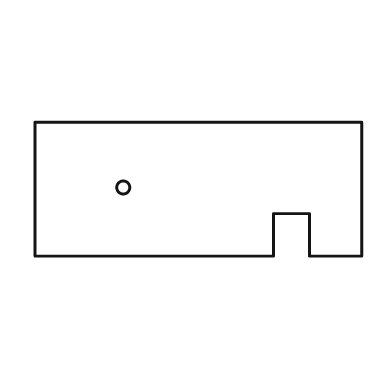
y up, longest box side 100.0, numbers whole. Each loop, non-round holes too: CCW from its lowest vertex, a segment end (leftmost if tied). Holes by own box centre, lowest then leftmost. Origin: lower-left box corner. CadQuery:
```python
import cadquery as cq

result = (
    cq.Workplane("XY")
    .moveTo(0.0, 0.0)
    .lineTo(73.0, 0.0)
    .lineTo(73.0, 13.0)
    .lineTo(84.0, 13.0)
    .lineTo(84.0, 0.0)
    .lineTo(100.0, 0.0)
    .lineTo(100.0, 41.0)
    .lineTo(0.0, 41.0)
    .close()
    .moveTo(27.0, 21.0)
    .circle(2.0)
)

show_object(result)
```